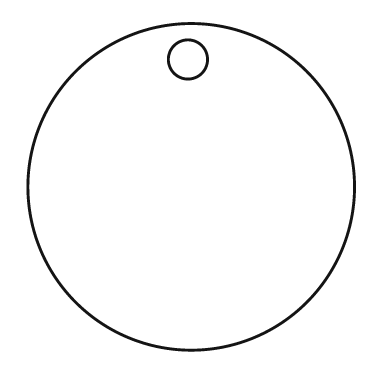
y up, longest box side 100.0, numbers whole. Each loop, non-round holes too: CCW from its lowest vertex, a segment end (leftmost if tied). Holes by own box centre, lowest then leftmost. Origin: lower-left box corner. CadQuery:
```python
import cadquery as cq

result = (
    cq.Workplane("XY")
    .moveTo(50.0, 50.0)
    .circle(50.0)
    .moveTo(49.0, 89.0)
    .circle(6.0)
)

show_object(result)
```